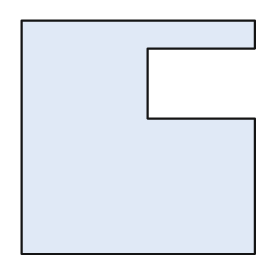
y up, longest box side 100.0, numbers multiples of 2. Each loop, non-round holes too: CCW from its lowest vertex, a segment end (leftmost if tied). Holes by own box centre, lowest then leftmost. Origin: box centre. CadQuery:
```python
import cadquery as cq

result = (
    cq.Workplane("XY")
    .moveTo(-50.0, -50.0)
    .lineTo(50.0, -50.0)
    .lineTo(50.0, 8.0)
    .lineTo(4.0, 8.0)
    .lineTo(4.0, 38.0)
    .lineTo(50.0, 38.0)
    .lineTo(50.0, 50.0)
    .lineTo(-50.0, 50.0)
    .close()
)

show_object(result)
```